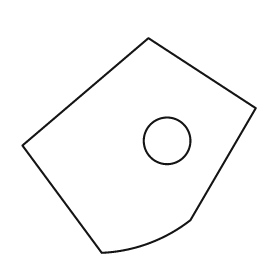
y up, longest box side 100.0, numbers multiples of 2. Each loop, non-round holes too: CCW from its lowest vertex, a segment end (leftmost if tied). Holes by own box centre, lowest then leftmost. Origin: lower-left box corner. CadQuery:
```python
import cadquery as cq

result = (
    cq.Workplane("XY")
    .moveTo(34.0, 0.0)
    .threePointArc((54.0, 4.0), (72.0, 14.0))
    .lineTo(100.0, 62.0)
    .lineTo(54.0, 92.0)
    .lineTo(0.0, 46.0)
    .close()
    .moveTo(62.0, 48.0)
    .circle(10.0)
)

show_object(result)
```